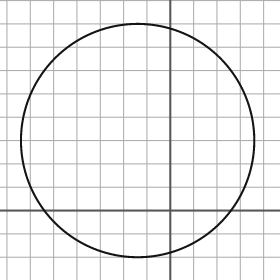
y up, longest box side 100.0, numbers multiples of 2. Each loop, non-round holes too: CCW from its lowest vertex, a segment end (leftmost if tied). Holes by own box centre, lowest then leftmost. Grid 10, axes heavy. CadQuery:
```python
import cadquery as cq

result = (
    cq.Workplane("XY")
    .moveTo(-14.0, 30.0)
    .circle(50.0)
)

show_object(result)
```